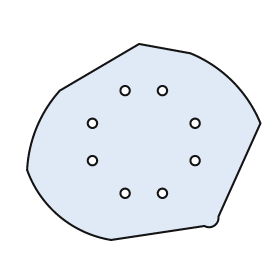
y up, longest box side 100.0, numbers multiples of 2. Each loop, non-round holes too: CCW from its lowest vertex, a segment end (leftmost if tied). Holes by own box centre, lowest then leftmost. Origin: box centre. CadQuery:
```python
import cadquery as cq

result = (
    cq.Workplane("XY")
    .moveTo(-14.0, -42.0)
    .lineTo(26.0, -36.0)
    .threePointArc((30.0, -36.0), (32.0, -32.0))
    .lineTo(50.0, 8.0)
    .threePointArc((38.0, 26.0), (20.0, 38.0))
    .lineTo(-2.0, 42.0)
    .lineTo(-36.0, 22.0)
    .threePointArc((-46.0, 6.0), (-50.0, -12.0))
    .threePointArc((-36.0, -32.0), (-14.0, -42.0))
    .close()
    .moveTo(-8.0, -22.0)
    .circle(2.0)
    .moveTo(8.0, -22.0)
    .circle(2.0)
    .moveTo(-22.0, -8.0)
    .circle(2.0)
    .moveTo(22.0, -8.0)
    .circle(2.0)
    .moveTo(-22.0, 8.0)
    .circle(2.0)
    .moveTo(22.0, 8.0)
    .circle(2.0)
    .moveTo(-8.0, 22.0)
    .circle(2.0)
    .moveTo(8.0, 22.0)
    .circle(2.0)
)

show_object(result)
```